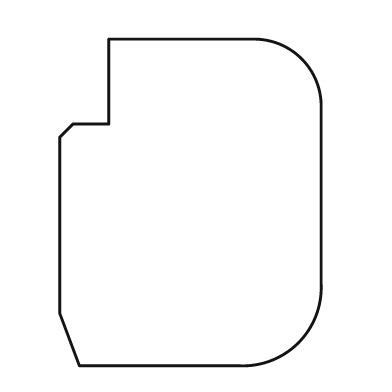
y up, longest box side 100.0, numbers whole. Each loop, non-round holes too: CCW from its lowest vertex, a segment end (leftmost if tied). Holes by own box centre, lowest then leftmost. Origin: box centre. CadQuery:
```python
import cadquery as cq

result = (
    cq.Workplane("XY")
    .moveTo(-34.0, -50.0)
    .lineTo(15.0, -50.0)
    .threePointArc((33.0, -43.0), (40.0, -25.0))
    .lineTo(40.0, 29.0)
    .threePointArc((34.0, 44.0), (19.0, 50.0))
    .lineTo(-25.0, 50.0)
    .lineTo(-25.0, 24.0)
    .lineTo(-36.0, 24.0)
    .lineTo(-40.0, 20.0)
    .lineTo(-40.0, -34.0)
    .close()
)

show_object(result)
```